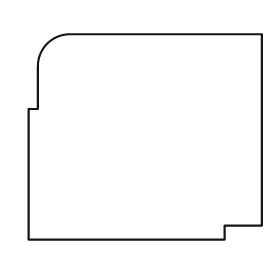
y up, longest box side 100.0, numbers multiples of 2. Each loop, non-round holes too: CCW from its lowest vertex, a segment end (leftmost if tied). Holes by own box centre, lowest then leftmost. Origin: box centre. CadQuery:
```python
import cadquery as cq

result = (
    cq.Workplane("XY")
    .moveTo(-50.0, -44.0)
    .lineTo(34.0, -44.0)
    .lineTo(34.0, -38.0)
    .lineTo(50.0, -38.0)
    .lineTo(50.0, 44.0)
    .lineTo(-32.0, 44.0)
    .threePointArc((-42.0, 40.0), (-46.0, 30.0))
    .lineTo(-46.0, 12.0)
    .lineTo(-50.0, 12.0)
    .close()
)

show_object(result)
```